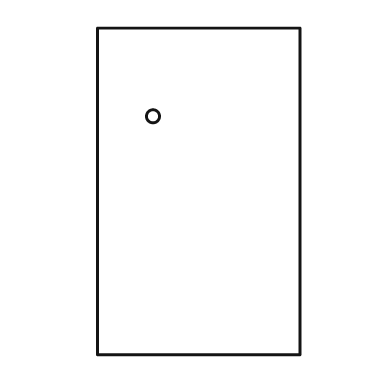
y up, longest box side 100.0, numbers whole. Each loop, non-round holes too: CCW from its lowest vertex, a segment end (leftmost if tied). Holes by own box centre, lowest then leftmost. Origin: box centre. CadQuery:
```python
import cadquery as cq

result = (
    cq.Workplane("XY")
    .moveTo(-31.0, -50.0)
    .lineTo(31.0, -50.0)
    .lineTo(31.0, 50.0)
    .lineTo(-31.0, 50.0)
    .close()
    .moveTo(-14.0, 23.0)
    .circle(2.0)
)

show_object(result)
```